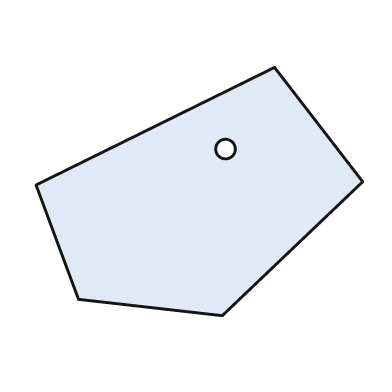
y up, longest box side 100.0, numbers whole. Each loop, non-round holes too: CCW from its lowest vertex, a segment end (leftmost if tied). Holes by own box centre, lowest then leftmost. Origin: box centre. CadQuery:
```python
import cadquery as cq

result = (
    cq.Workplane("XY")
    .moveTo(7.0, -38.0)
    .lineTo(50.0, 3.0)
    .lineTo(23.0, 38.0)
    .lineTo(-50.0, 2.0)
    .lineTo(-37.0, -33.0)
    .close()
    .moveTo(8.0, 13.0)
    .circle(3.0)
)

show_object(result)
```